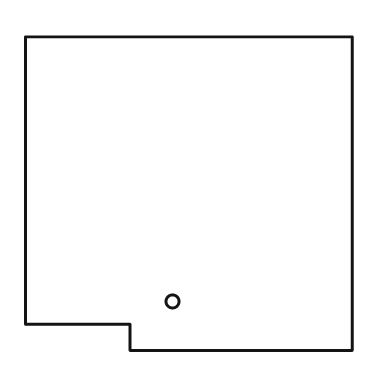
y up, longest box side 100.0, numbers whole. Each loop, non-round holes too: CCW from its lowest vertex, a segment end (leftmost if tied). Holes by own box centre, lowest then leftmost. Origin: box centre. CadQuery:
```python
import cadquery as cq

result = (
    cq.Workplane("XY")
    .moveTo(-18.0, -48.0)
    .lineTo(50.0, -48.0)
    .lineTo(50.0, 48.0)
    .lineTo(-50.0, 48.0)
    .lineTo(-50.0, -40.0)
    .lineTo(-18.0, -40.0)
    .close()
    .moveTo(-5.0, -33.0)
    .circle(2.0)
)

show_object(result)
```